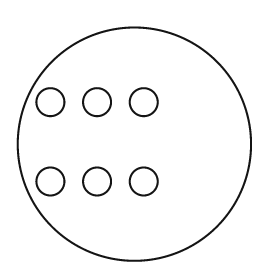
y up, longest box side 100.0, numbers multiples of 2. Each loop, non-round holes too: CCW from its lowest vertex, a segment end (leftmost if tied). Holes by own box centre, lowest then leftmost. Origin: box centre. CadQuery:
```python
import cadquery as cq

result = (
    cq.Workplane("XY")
    .moveTo(0.0, 0.0)
    .circle(50.0)
    .moveTo(-36.0, -16.0)
    .circle(6.0)
    .moveTo(-16.0, -16.0)
    .circle(6.0)
    .moveTo(4.0, -16.0)
    .circle(6.0)
    .moveTo(-36.0, 18.0)
    .circle(6.0)
    .moveTo(-16.0, 18.0)
    .circle(6.0)
    .moveTo(4.0, 18.0)
    .circle(6.0)
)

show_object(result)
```